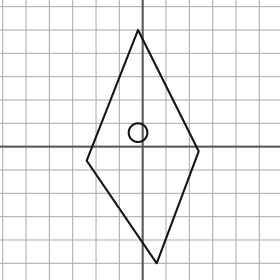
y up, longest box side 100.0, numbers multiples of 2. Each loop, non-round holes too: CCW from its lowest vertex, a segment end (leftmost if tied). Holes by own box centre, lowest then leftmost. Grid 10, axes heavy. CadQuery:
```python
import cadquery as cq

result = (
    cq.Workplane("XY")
    .moveTo(6.0, -50.0)
    .lineTo(24.0, -2.0)
    .lineTo(-2.0, 50.0)
    .lineTo(-24.0, -6.0)
    .close()
    .moveTo(-2.0, 6.0)
    .circle(4.0)
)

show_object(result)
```